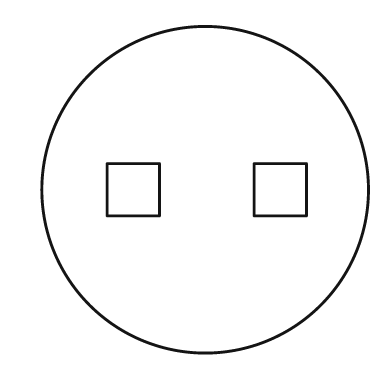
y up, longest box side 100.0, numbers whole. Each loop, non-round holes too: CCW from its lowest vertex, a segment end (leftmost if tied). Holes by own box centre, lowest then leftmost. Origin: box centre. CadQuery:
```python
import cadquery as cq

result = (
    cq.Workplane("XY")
    .moveTo(0.0, 0.0)
    .circle(50.0)
    .moveTo(-30.0, -8.0)
    .lineTo(-14.0, -8.0)
    .lineTo(-14.0, 8.0)
    .lineTo(-30.0, 8.0)
    .close()
    .moveTo(15.0, -8.0)
    .lineTo(31.0, -8.0)
    .lineTo(31.0, 8.0)
    .lineTo(15.0, 8.0)
    .close()
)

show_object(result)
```